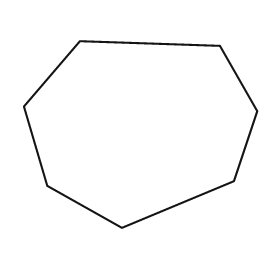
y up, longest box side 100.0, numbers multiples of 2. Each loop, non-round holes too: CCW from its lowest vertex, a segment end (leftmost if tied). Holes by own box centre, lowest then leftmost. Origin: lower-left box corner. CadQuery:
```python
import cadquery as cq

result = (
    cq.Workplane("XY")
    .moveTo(42.0, 0.0)
    .lineTo(90.0, 20.0)
    .lineTo(100.0, 50.0)
    .lineTo(84.0, 78.0)
    .lineTo(24.0, 80.0)
    .lineTo(0.0, 52.0)
    .lineTo(10.0, 18.0)
    .close()
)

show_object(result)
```